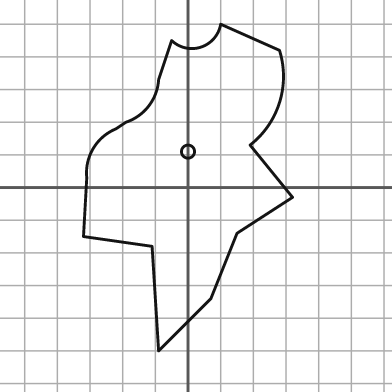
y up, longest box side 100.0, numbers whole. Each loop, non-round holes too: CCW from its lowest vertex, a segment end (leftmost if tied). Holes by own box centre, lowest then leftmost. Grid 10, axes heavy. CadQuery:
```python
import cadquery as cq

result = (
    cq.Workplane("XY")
    .moveTo(-9.0, -50.0)
    .lineTo(7.0, -34.0)
    .lineTo(15.0, -14.0)
    .lineTo(32.0, -3.0)
    .lineTo(19.0, 13.0)
    .threePointArc((28.0, 26.0), (28.0, 42.0))
    .lineTo(10.0, 50.0)
    .threePointArc((4.0, 43.0), (-5.0, 45.0))
    .lineTo(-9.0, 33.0)
    .threePointArc((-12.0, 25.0), (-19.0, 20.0))
    .lineTo(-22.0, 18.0)
    .threePointArc((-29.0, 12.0), (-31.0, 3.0))
    .lineTo(-32.0, -15.0)
    .lineTo(-11.0, -18.0)
    .close()
    .moveTo(0.0, 11.0)
    .circle(2.0)
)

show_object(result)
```